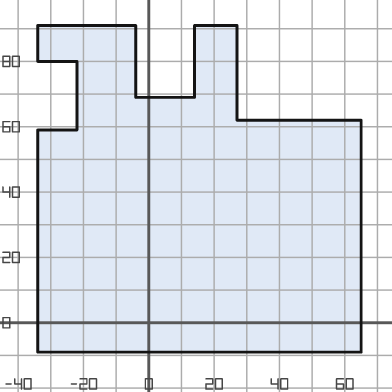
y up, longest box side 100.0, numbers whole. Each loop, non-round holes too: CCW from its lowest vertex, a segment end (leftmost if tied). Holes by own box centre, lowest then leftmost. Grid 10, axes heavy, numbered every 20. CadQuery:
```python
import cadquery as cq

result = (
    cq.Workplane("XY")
    .moveTo(-34.0, -9.0)
    .lineTo(65.0, -9.0)
    .lineTo(65.0, 62.0)
    .lineTo(27.0, 62.0)
    .lineTo(27.0, 91.0)
    .lineTo(14.0, 91.0)
    .lineTo(14.0, 69.0)
    .lineTo(-4.0, 69.0)
    .lineTo(-4.0, 91.0)
    .lineTo(-34.0, 91.0)
    .lineTo(-34.0, 80.0)
    .lineTo(-22.0, 80.0)
    .lineTo(-22.0, 59.0)
    .lineTo(-34.0, 59.0)
    .close()
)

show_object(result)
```